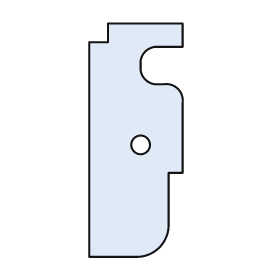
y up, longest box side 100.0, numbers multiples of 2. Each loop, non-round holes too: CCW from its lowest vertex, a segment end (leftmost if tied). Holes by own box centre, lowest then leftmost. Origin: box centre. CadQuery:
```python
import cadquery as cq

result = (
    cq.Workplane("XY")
    .moveTo(-20.0, -50.0)
    .lineTo(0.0, -50.0)
    .threePointArc((10.0, -46.0), (14.0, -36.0))
    .lineTo(14.0, -14.0)
    .lineTo(20.0, -14.0)
    .lineTo(20.0, 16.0)
    .threePointArc((18.0, 22.0), (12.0, 24.0))
    .lineTo(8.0, 24.0)
    .threePointArc((4.0, 26.0), (2.0, 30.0))
    .lineTo(2.0, 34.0)
    .threePointArc((4.0, 38.0), (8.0, 40.0))
    .lineTo(20.0, 40.0)
    .lineTo(20.0, 50.0)
    .lineTo(-12.0, 50.0)
    .lineTo(-12.0, 42.0)
    .lineTo(-20.0, 42.0)
    .close()
    .moveTo(2.0, -2.0)
    .circle(4.0)
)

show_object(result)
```